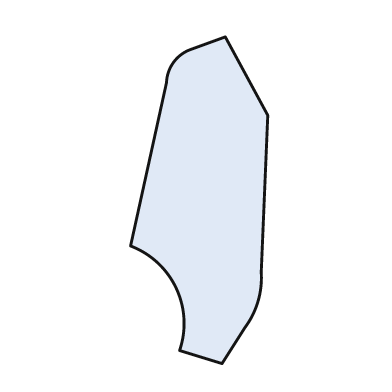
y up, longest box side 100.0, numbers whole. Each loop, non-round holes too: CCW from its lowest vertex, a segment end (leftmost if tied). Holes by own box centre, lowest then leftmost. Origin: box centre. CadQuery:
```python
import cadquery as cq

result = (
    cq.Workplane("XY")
    .moveTo(7.0, -50.0)
    .lineTo(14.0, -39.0)
    .threePointArc((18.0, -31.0), (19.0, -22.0))
    .lineTo(21.0, 26.0)
    .lineTo(8.0, 50.0)
    .lineTo(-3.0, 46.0)
    .threePointArc((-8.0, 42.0), (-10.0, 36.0))
    .lineTo(-21.0, -14.0)
    .threePointArc((-7.0, -27.0), (-6.0, -46.0))
    .close()
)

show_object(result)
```